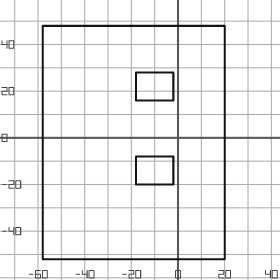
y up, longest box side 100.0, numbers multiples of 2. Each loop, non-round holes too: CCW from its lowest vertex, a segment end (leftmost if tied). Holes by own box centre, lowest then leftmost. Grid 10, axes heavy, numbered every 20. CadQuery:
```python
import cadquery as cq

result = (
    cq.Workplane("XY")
    .moveTo(-58.0, -52.0)
    .lineTo(20.0, -52.0)
    .lineTo(20.0, 48.0)
    .lineTo(-58.0, 48.0)
    .close()
    .moveTo(-18.0, -20.0)
    .lineTo(-2.0, -20.0)
    .lineTo(-2.0, -8.0)
    .lineTo(-18.0, -8.0)
    .close()
    .moveTo(-18.0, 16.0)
    .lineTo(-2.0, 16.0)
    .lineTo(-2.0, 28.0)
    .lineTo(-18.0, 28.0)
    .close()
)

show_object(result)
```